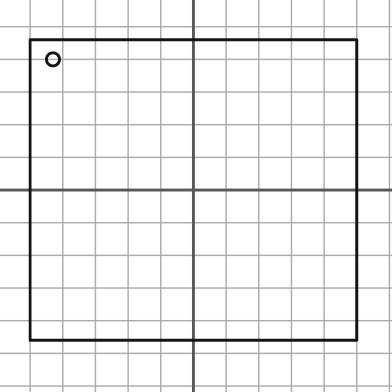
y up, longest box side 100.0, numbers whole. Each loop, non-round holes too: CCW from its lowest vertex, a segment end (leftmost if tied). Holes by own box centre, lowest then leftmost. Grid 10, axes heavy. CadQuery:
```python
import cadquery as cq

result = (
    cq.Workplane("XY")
    .moveTo(-50.0, -46.0)
    .lineTo(50.0, -46.0)
    .lineTo(50.0, 46.0)
    .lineTo(-50.0, 46.0)
    .close()
    .moveTo(-43.0, 40.0)
    .circle(2.0)
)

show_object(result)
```